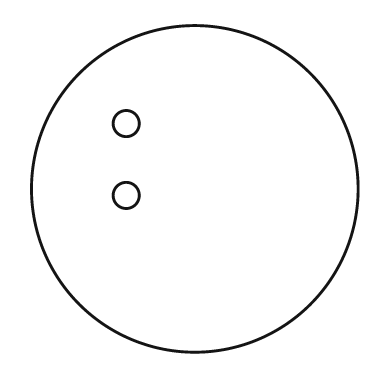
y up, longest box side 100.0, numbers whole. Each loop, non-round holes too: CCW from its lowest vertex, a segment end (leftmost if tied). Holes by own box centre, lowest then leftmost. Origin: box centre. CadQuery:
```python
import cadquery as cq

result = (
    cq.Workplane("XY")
    .moveTo(0.0, 0.0)
    .circle(50.0)
    .moveTo(-21.0, -2.0)
    .circle(4.0)
    .moveTo(-21.0, 20.0)
    .circle(4.0)
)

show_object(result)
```